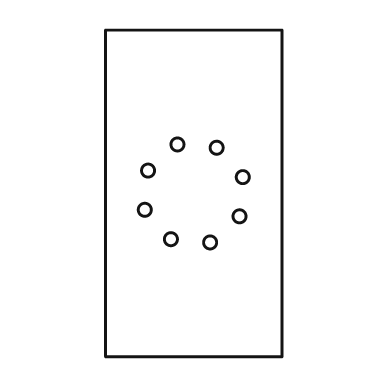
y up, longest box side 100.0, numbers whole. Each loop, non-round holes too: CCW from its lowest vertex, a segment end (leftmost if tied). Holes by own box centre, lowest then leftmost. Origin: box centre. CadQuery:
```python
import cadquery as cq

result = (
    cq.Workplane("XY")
    .moveTo(-27.0, -50.0)
    .lineTo(27.0, -50.0)
    .lineTo(27.0, 50.0)
    .lineTo(-27.0, 50.0)
    .close()
    .moveTo(5.0, -15.0)
    .circle(2.0)
    .moveTo(-7.0, -14.0)
    .circle(2.0)
    .moveTo(14.0, -7.0)
    .circle(2.0)
    .moveTo(-15.0, -5.0)
    .circle(2.0)
    .moveTo(15.0, 5.0)
    .circle(2.0)
    .moveTo(-14.0, 7.0)
    .circle(2.0)
    .moveTo(7.0, 14.0)
    .circle(2.0)
    .moveTo(-5.0, 15.0)
    .circle(2.0)
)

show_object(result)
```